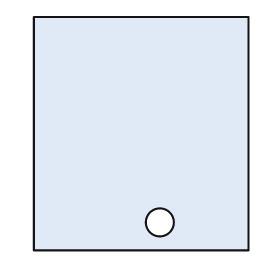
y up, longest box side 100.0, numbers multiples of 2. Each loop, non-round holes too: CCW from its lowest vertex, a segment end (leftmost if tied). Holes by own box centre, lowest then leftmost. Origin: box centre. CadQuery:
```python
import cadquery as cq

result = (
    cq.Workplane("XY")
    .moveTo(-46.0, -50.0)
    .lineTo(46.0, -50.0)
    .lineTo(46.0, 50.0)
    .lineTo(-46.0, 50.0)
    .close()
    .moveTo(8.0, -38.0)
    .circle(6.0)
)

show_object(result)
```